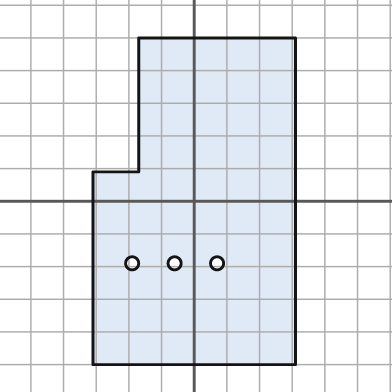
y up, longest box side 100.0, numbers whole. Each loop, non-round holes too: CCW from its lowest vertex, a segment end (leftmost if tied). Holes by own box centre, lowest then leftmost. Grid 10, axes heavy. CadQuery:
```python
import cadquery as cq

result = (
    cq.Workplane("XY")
    .moveTo(-31.0, -50.0)
    .lineTo(31.0, -50.0)
    .lineTo(31.0, 50.0)
    .lineTo(-17.0, 50.0)
    .lineTo(-17.0, 9.0)
    .lineTo(-31.0, 9.0)
    .close()
    .moveTo(-19.0, -19.0)
    .circle(2.0)
    .moveTo(-6.0, -19.0)
    .circle(2.0)
    .moveTo(7.0, -19.0)
    .circle(2.0)
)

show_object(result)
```